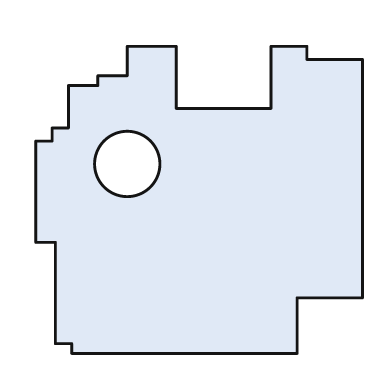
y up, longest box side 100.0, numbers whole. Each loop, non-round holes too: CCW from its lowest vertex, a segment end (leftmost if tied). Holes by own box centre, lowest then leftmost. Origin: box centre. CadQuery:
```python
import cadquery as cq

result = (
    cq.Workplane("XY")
    .moveTo(-39.0, -47.0)
    .lineTo(30.0, -47.0)
    .lineTo(30.0, -30.0)
    .lineTo(50.0, -30.0)
    .lineTo(50.0, 43.0)
    .lineTo(33.0, 43.0)
    .lineTo(33.0, 47.0)
    .lineTo(22.0, 47.0)
    .lineTo(22.0, 28.0)
    .lineTo(-7.0, 28.0)
    .lineTo(-7.0, 47.0)
    .lineTo(-22.0, 47.0)
    .lineTo(-22.0, 38.0)
    .lineTo(-31.0, 38.0)
    .lineTo(-31.0, 35.0)
    .lineTo(-40.0, 35.0)
    .lineTo(-40.0, 22.0)
    .lineTo(-45.0, 22.0)
    .lineTo(-45.0, 18.0)
    .lineTo(-50.0, 18.0)
    .lineTo(-50.0, -13.0)
    .lineTo(-44.0, -13.0)
    .lineTo(-44.0, -44.0)
    .lineTo(-39.0, -44.0)
    .close()
    .moveTo(-22.0, 11.0)
    .circle(10.0)
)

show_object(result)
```